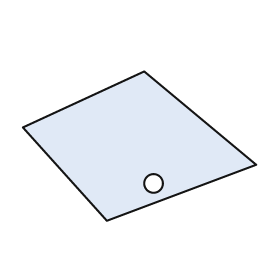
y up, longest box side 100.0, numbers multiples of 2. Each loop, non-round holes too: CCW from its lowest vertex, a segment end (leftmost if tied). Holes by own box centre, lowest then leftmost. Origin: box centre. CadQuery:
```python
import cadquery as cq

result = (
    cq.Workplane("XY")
    .moveTo(-14.0, -32.0)
    .lineTo(50.0, -8.0)
    .lineTo(2.0, 32.0)
    .lineTo(-50.0, 8.0)
    .close()
    .moveTo(6.0, -16.0)
    .circle(4.0)
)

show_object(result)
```